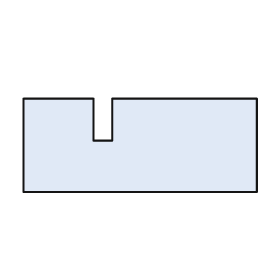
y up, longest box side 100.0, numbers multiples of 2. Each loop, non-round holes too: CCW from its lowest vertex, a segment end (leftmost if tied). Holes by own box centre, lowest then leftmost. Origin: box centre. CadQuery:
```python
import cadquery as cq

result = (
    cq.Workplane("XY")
    .moveTo(-50.0, -20.0)
    .lineTo(50.0, -20.0)
    .lineTo(50.0, 20.0)
    .lineTo(-12.0, 20.0)
    .lineTo(-12.0, 2.0)
    .lineTo(-20.0, 2.0)
    .lineTo(-20.0, 20.0)
    .lineTo(-50.0, 20.0)
    .close()
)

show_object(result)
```